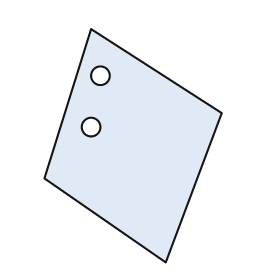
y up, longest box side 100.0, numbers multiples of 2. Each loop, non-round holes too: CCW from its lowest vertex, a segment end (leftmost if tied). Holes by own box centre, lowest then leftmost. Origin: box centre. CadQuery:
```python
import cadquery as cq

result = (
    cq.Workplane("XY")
    .moveTo(14.0, -50.0)
    .lineTo(38.0, 14.0)
    .lineTo(-18.0, 50.0)
    .lineTo(-38.0, -14.0)
    .close()
    .moveTo(-18.0, 8.0)
    .circle(4.0)
    .moveTo(-14.0, 30.0)
    .circle(4.0)
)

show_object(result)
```